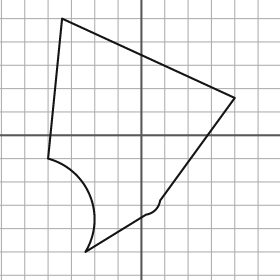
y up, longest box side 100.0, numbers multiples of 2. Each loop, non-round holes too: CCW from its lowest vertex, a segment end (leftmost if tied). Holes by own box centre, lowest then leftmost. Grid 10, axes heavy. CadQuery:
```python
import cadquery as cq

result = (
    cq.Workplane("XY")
    .moveTo(-24.0, -50.0)
    .lineTo(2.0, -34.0)
    .threePointArc((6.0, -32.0), (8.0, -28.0))
    .lineTo(40.0, 16.0)
    .lineTo(-34.0, 50.0)
    .lineTo(-40.0, -10.0)
    .threePointArc((-22.0, -26.0), (-24.0, -50.0))
    .close()
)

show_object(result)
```